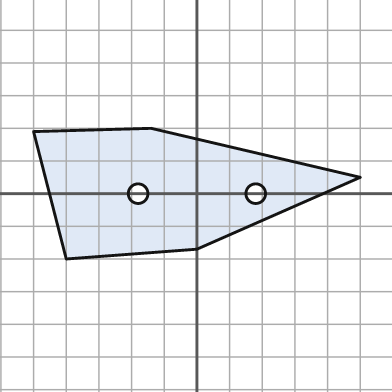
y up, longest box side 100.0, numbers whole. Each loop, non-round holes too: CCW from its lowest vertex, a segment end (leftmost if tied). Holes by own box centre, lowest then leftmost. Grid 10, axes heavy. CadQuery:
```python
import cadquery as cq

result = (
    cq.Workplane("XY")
    .moveTo(-40.0, -20.0)
    .lineTo(0.0, -17.0)
    .lineTo(50.0, 5.0)
    .lineTo(-14.0, 20.0)
    .lineTo(-50.0, 19.0)
    .close()
    .moveTo(-18.0, 0.0)
    .circle(3.0)
    .moveTo(18.0, 0.0)
    .circle(3.0)
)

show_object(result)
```